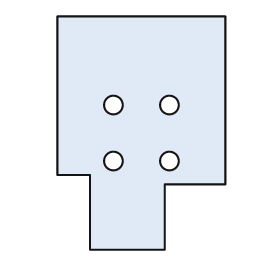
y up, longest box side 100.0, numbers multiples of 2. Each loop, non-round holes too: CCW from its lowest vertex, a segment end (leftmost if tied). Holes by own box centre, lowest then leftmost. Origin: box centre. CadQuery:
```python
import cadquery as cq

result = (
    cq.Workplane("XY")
    .moveTo(-22.0, -50.0)
    .lineTo(10.0, -50.0)
    .lineTo(10.0, -22.0)
    .lineTo(36.0, -22.0)
    .lineTo(36.0, 50.0)
    .lineTo(-36.0, 50.0)
    .lineTo(-36.0, -18.0)
    .lineTo(-22.0, -18.0)
    .close()
    .moveTo(-12.0, -12.0)
    .circle(4.0)
    .moveTo(12.0, -12.0)
    .circle(4.0)
    .moveTo(-12.0, 12.0)
    .circle(4.0)
    .moveTo(12.0, 12.0)
    .circle(4.0)
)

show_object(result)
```